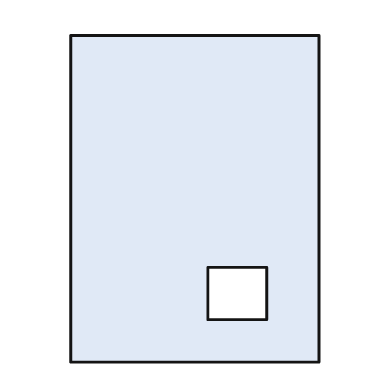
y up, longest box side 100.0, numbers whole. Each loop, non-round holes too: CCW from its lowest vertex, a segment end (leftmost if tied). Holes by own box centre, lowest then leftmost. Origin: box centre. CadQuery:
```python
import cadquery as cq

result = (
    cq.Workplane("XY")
    .moveTo(-38.0, -50.0)
    .lineTo(38.0, -50.0)
    .lineTo(38.0, 50.0)
    .lineTo(-38.0, 50.0)
    .close()
    .moveTo(4.0, -37.0)
    .lineTo(22.0, -37.0)
    .lineTo(22.0, -21.0)
    .lineTo(4.0, -21.0)
    .close()
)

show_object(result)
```